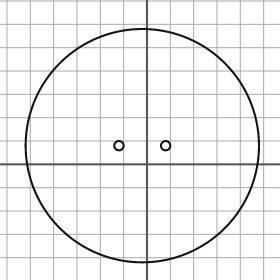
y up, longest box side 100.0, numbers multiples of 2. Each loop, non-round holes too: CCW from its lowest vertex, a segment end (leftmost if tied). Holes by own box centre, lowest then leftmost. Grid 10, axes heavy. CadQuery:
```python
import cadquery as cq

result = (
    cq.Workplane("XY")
    .moveTo(-2.0, 8.0)
    .circle(50.0)
    .moveTo(-12.0, 8.0)
    .circle(2.0)
    .moveTo(8.0, 8.0)
    .circle(2.0)
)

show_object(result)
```